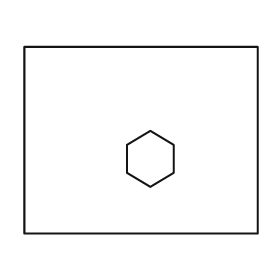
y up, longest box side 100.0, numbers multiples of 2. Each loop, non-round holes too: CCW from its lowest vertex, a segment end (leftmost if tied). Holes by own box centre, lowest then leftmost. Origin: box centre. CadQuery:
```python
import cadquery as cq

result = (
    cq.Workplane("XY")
    .moveTo(-50.0, -40.0)
    .lineTo(50.0, -40.0)
    .lineTo(50.0, 40.0)
    .lineTo(-50.0, 40.0)
    .close()
    .moveTo(4.0, -20.0)
    .lineTo(14.0, -14.0)
    .lineTo(14.0, -2.0)
    .lineTo(4.0, 4.0)
    .lineTo(-6.0, -2.0)
    .lineTo(-6.0, -14.0)
    .close()
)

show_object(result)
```